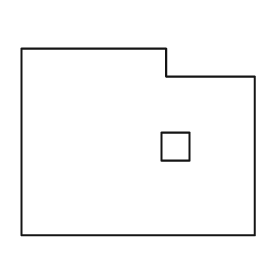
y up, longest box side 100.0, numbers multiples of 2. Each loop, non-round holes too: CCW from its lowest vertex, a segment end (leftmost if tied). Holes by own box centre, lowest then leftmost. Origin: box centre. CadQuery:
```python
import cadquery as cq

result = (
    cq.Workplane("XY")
    .moveTo(-50.0, -40.0)
    .lineTo(50.0, -40.0)
    .lineTo(50.0, 28.0)
    .lineTo(12.0, 28.0)
    .lineTo(12.0, 40.0)
    .lineTo(-50.0, 40.0)
    .close()
    .moveTo(10.0, -8.0)
    .lineTo(22.0, -8.0)
    .lineTo(22.0, 4.0)
    .lineTo(10.0, 4.0)
    .close()
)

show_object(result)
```